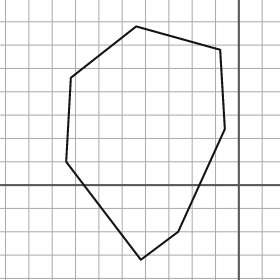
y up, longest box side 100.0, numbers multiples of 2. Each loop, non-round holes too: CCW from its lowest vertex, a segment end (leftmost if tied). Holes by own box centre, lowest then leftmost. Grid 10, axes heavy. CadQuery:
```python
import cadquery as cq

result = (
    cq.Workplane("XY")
    .moveTo(-42.0, -32.0)
    .lineTo(-26.0, -20.0)
    .lineTo(-6.0, 24.0)
    .lineTo(-8.0, 58.0)
    .lineTo(-44.0, 68.0)
    .lineTo(-72.0, 46.0)
    .lineTo(-74.0, 10.0)
    .close()
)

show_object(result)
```